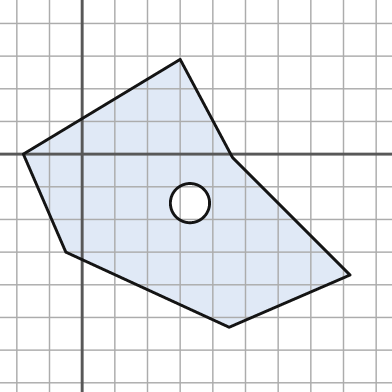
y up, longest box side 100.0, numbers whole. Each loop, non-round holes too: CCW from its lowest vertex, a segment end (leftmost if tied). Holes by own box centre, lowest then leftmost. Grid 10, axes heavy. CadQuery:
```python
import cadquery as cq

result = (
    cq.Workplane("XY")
    .moveTo(45.0, -53.0)
    .lineTo(82.0, -37.0)
    .lineTo(46.0, -1.0)
    .lineTo(30.0, 29.0)
    .lineTo(-18.0, 0.0)
    .lineTo(-5.0, -30.0)
    .close()
    .moveTo(33.0, -15.0)
    .circle(6.0)
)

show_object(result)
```